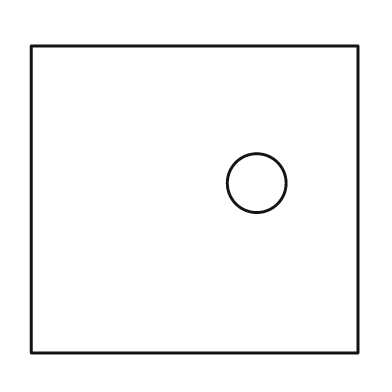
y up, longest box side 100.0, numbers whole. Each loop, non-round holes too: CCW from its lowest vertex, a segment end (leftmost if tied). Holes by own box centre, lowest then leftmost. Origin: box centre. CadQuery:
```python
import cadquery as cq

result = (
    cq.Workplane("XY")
    .moveTo(-50.0, -47.0)
    .lineTo(50.0, -47.0)
    .lineTo(50.0, 47.0)
    .lineTo(-50.0, 47.0)
    .close()
    .moveTo(19.0, 5.0)
    .circle(9.0)
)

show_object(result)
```